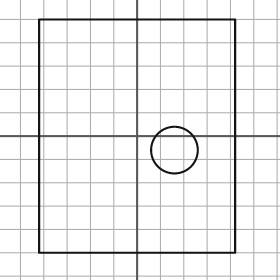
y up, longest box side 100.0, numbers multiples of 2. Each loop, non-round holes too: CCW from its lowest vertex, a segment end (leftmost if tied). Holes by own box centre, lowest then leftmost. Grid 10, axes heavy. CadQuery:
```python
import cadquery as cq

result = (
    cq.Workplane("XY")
    .moveTo(-42.0, -50.0)
    .lineTo(42.0, -50.0)
    .lineTo(42.0, 50.0)
    .lineTo(-42.0, 50.0)
    .close()
    .moveTo(16.0, -6.0)
    .circle(10.0)
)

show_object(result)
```